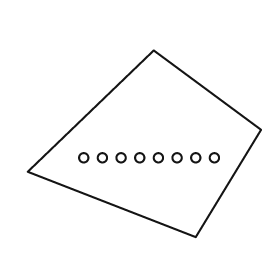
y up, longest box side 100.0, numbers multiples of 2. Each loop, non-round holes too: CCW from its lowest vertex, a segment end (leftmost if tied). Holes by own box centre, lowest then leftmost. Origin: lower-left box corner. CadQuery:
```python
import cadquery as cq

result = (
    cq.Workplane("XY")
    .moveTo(72.0, 0.0)
    .lineTo(100.0, 46.0)
    .lineTo(54.0, 80.0)
    .lineTo(0.0, 28.0)
    .close()
    .moveTo(24.0, 34.0)
    .circle(2.0)
    .moveTo(32.0, 34.0)
    .circle(2.0)
    .moveTo(40.0, 34.0)
    .circle(2.0)
    .moveTo(48.0, 34.0)
    .circle(2.0)
    .moveTo(56.0, 34.0)
    .circle(2.0)
    .moveTo(64.0, 34.0)
    .circle(2.0)
    .moveTo(72.0, 34.0)
    .circle(2.0)
    .moveTo(80.0, 34.0)
    .circle(2.0)
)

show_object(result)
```